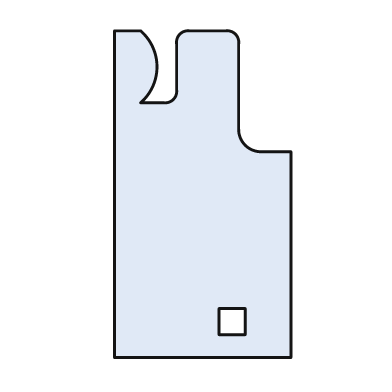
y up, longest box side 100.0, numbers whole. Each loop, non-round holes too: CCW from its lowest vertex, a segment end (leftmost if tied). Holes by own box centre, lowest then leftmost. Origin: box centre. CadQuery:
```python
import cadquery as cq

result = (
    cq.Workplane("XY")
    .moveTo(-27.0, -50.0)
    .lineTo(27.0, -50.0)
    .lineTo(27.0, 13.0)
    .lineTo(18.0, 13.0)
    .threePointArc((13.0, 15.0), (11.0, 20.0))
    .lineTo(11.0, 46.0)
    .threePointArc((10.0, 49.0), (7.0, 50.0))
    .lineTo(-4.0, 50.0)
    .threePointArc((-7.0, 49.0), (-8.0, 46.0))
    .lineTo(-8.0, 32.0)
    .threePointArc((-9.0, 29.0), (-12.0, 28.0))
    .lineTo(-19.0, 28.0)
    .threePointArc((-14.0, 39.0), (-19.0, 50.0))
    .lineTo(-27.0, 50.0)
    .close()
    .moveTo(5.0, -43.0)
    .lineTo(13.0, -43.0)
    .lineTo(13.0, -35.0)
    .lineTo(5.0, -35.0)
    .close()
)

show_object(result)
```